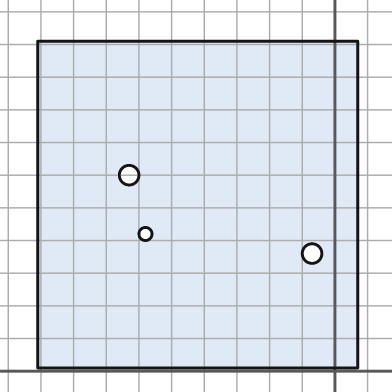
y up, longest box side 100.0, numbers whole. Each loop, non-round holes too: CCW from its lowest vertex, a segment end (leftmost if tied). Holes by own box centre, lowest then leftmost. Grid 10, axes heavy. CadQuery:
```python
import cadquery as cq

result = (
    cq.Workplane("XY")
    .moveTo(-91.0, 1.0)
    .lineTo(7.0, 1.0)
    .lineTo(7.0, 101.0)
    .lineTo(-91.0, 101.0)
    .close()
    .moveTo(-7.0, 36.0)
    .circle(3.0)
    .moveTo(-58.0, 42.0)
    .circle(2.0)
    .moveTo(-63.0, 60.0)
    .circle(3.0)
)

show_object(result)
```